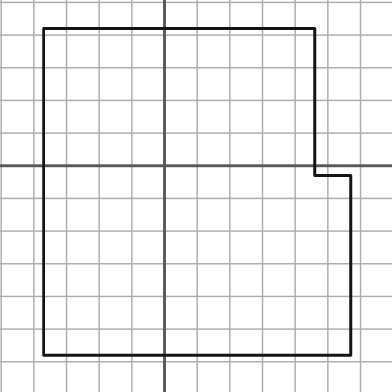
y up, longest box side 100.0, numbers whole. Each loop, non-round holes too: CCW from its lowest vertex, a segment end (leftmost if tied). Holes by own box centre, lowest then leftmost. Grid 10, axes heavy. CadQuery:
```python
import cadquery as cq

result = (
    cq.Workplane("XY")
    .moveTo(-37.0, -58.0)
    .lineTo(57.0, -58.0)
    .lineTo(57.0, -3.0)
    .lineTo(46.0, -3.0)
    .lineTo(46.0, 42.0)
    .lineTo(-37.0, 42.0)
    .close()
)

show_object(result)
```